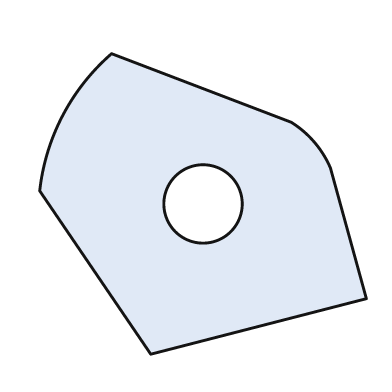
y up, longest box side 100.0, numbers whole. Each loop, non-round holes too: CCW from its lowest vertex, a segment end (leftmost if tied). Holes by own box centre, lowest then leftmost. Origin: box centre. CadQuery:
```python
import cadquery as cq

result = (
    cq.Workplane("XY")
    .moveTo(-16.0, -46.0)
    .lineTo(50.0, -29.0)
    .lineTo(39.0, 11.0)
    .threePointArc((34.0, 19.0), (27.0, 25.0))
    .lineTo(-28.0, 46.0)
    .threePointArc((-43.0, 27.0), (-50.0, 4.0))
    .close()
    .moveTo(0.0, 0.0)
    .circle(12.0)
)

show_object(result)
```